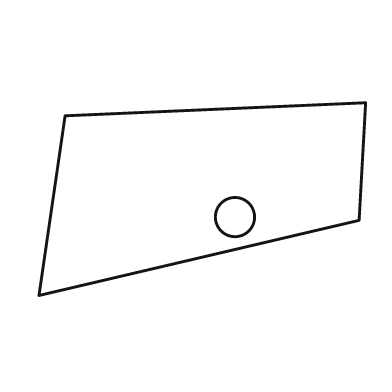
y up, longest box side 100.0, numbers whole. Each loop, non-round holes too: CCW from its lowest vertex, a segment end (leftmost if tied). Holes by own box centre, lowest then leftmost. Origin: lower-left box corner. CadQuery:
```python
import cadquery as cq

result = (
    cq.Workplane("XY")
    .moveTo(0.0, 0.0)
    .lineTo(98.0, 23.0)
    .lineTo(100.0, 59.0)
    .lineTo(8.0, 55.0)
    .close()
    .moveTo(60.0, 24.0)
    .circle(6.0)
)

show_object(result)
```